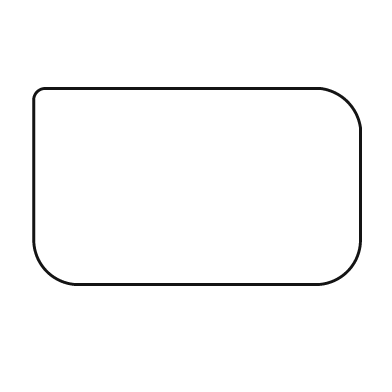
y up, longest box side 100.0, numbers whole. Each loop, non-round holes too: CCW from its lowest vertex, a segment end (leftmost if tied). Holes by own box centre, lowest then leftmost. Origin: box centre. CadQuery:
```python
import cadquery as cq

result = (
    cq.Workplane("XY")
    .moveTo(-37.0, -30.0)
    .lineTo(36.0, -30.0)
    .threePointArc((46.0, -26.0), (50.0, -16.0))
    .lineTo(50.0, 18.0)
    .threePointArc((46.0, 26.0), (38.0, 30.0))
    .lineTo(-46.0, 30.0)
    .threePointArc((-49.0, 29.0), (-50.0, 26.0))
    .lineTo(-50.0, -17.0)
    .threePointArc((-46.0, -26.0), (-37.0, -30.0))
    .close()
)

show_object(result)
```